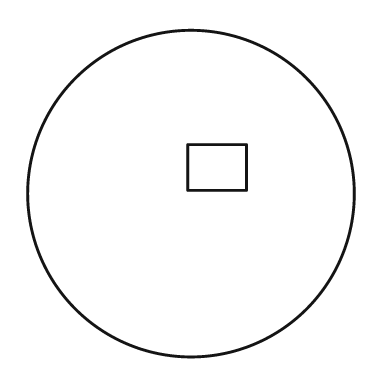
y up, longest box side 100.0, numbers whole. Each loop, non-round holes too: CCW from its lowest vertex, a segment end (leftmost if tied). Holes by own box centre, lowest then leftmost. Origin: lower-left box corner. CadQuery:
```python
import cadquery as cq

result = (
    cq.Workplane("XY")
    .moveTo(50.0, 50.0)
    .circle(50.0)
    .moveTo(49.0, 51.0)
    .lineTo(67.0, 51.0)
    .lineTo(67.0, 65.0)
    .lineTo(49.0, 65.0)
    .close()
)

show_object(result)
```